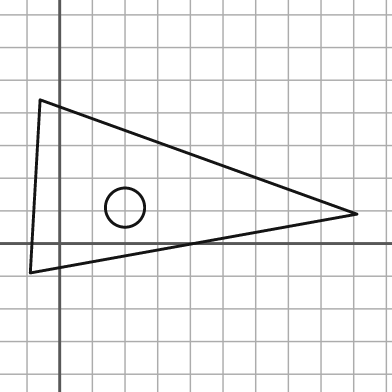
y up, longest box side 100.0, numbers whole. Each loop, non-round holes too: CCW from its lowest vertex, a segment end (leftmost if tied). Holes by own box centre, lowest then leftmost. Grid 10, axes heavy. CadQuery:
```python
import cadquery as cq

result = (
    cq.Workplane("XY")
    .moveTo(-9.0, -9.0)
    .lineTo(91.0, 9.0)
    .lineTo(-6.0, 44.0)
    .close()
    .moveTo(20.0, 11.0)
    .circle(6.0)
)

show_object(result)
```